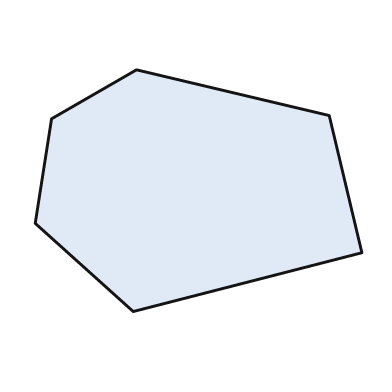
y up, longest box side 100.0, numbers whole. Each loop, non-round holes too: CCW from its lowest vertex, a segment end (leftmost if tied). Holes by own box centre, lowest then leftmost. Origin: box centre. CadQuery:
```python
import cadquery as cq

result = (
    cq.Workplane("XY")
    .moveTo(-20.0, -37.0)
    .lineTo(50.0, -19.0)
    .lineTo(40.0, 23.0)
    .lineTo(-19.0, 37.0)
    .lineTo(-45.0, 22.0)
    .lineTo(-50.0, -10.0)
    .close()
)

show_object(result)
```